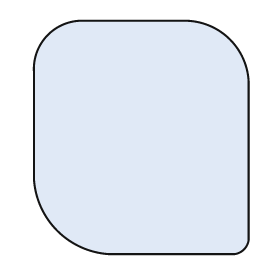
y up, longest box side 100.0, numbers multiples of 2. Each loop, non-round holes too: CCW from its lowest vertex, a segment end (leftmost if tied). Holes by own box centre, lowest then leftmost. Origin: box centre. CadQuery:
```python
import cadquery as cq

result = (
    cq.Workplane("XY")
    .moveTo(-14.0, -50.0)
    .lineTo(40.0, -50.0)
    .threePointArc((44.0, -48.0), (46.0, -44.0))
    .lineTo(46.0, 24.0)
    .threePointArc((38.0, 42.0), (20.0, 50.0))
    .lineTo(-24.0, 50.0)
    .threePointArc((-40.0, 44.0), (-46.0, 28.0))
    .lineTo(-46.0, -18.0)
    .threePointArc((-36.0, -40.0), (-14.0, -50.0))
    .close()
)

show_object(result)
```